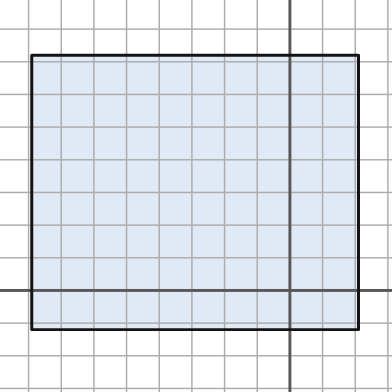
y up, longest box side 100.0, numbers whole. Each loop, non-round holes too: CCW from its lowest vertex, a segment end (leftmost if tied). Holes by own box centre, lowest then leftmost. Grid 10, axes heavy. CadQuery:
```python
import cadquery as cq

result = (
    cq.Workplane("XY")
    .moveTo(-79.0, -12.0)
    .lineTo(21.0, -12.0)
    .lineTo(21.0, 72.0)
    .lineTo(-79.0, 72.0)
    .close()
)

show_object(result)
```